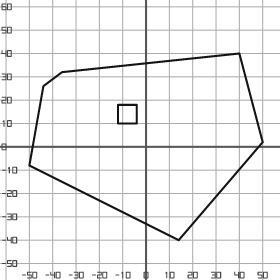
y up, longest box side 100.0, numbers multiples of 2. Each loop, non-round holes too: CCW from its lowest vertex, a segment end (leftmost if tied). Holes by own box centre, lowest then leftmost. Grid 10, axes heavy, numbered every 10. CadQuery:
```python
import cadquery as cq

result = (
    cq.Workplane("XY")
    .moveTo(14.0, -40.0)
    .lineTo(50.0, 2.0)
    .lineTo(40.0, 40.0)
    .lineTo(-36.0, 32.0)
    .lineTo(-44.0, 26.0)
    .lineTo(-50.0, -8.0)
    .close()
    .moveTo(-12.0, 10.0)
    .lineTo(-4.0, 10.0)
    .lineTo(-4.0, 18.0)
    .lineTo(-12.0, 18.0)
    .close()
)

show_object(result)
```